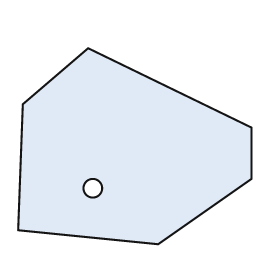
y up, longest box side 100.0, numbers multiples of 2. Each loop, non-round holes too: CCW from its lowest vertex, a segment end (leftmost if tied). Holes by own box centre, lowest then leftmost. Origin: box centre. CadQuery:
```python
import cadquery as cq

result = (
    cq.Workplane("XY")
    .moveTo(10.0, -42.0)
    .lineTo(50.0, -14.0)
    .lineTo(50.0, 8.0)
    .lineTo(-20.0, 42.0)
    .lineTo(-48.0, 18.0)
    .lineTo(-50.0, -36.0)
    .close()
    .moveTo(-18.0, -18.0)
    .circle(4.0)
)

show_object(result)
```